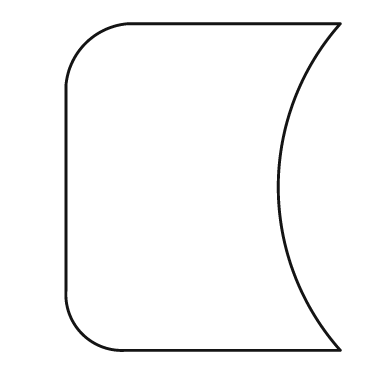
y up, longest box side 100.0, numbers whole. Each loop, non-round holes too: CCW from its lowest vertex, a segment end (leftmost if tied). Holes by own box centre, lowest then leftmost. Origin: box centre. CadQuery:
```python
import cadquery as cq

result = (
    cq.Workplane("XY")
    .moveTo(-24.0, -50.0)
    .lineTo(42.0, -50.0)
    .threePointArc((23.0, 0.0), (42.0, 50.0))
    .lineTo(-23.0, 50.0)
    .threePointArc((-36.0, 44.0), (-42.0, 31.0))
    .lineTo(-42.0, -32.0)
    .threePointArc((-37.0, -45.0), (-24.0, -50.0))
    .close()
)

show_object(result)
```